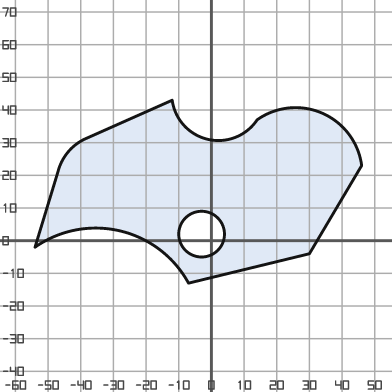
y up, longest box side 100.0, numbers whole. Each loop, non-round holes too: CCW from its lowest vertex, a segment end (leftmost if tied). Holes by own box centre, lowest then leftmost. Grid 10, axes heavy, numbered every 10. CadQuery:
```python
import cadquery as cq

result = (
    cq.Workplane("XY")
    .moveTo(-7.0, -13.0)
    .lineTo(30.0, -4.0)
    .lineTo(46.0, 23.0)
    .threePointArc((34.0, 39.0), (14.0, 37.0))
    .threePointArc((-1.0, 31.0), (-12.0, 43.0))
    .lineTo(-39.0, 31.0)
    .threePointArc((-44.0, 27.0), (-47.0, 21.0))
    .lineTo(-54.0, -2.0)
    .threePointArc((-28.0, 3.0), (-7.0, -13.0))
    .close()
    .moveTo(-3.0, 2.0)
    .circle(7.0)
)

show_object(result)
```